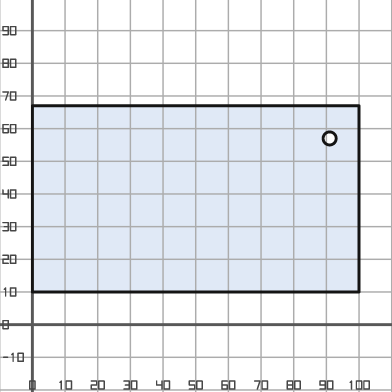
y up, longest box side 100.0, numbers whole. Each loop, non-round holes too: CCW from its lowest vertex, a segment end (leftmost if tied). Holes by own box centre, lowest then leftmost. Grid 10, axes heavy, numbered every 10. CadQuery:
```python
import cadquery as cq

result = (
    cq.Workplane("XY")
    .moveTo(0.0, 10.0)
    .lineTo(100.0, 10.0)
    .lineTo(100.0, 67.0)
    .lineTo(0.0, 67.0)
    .close()
    .moveTo(91.0, 57.0)
    .circle(2.0)
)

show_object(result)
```